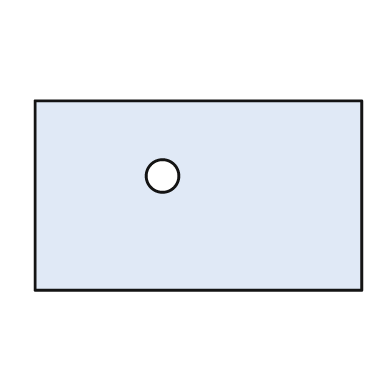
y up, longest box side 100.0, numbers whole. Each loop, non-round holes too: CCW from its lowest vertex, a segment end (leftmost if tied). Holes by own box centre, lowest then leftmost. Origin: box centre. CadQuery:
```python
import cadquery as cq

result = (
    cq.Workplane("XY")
    .moveTo(-50.0, -29.0)
    .lineTo(50.0, -29.0)
    .lineTo(50.0, 29.0)
    .lineTo(-50.0, 29.0)
    .close()
    .moveTo(-11.0, 6.0)
    .circle(5.0)
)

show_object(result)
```